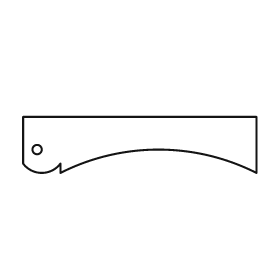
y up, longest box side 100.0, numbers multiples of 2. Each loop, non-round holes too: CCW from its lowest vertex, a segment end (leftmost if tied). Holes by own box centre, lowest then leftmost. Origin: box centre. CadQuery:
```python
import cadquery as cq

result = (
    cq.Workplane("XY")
    .moveTo(-34.0, -12.0)
    .threePointArc((8.0, -2.0), (50.0, -12.0))
    .lineTo(50.0, 12.0)
    .lineTo(-50.0, 12.0)
    .lineTo(-50.0, -8.0)
    .threePointArc((-42.0, -12.0), (-34.0, -8.0))
    .close()
    .moveTo(-44.0, -2.0)
    .circle(2.0)
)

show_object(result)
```